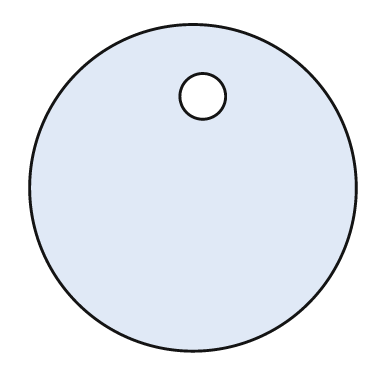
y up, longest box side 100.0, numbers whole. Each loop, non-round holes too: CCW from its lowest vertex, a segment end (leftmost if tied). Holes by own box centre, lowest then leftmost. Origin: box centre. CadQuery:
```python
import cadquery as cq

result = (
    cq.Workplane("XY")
    .moveTo(0.0, 0.0)
    .circle(50.0)
    .moveTo(3.0, 28.0)
    .circle(7.0)
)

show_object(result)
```